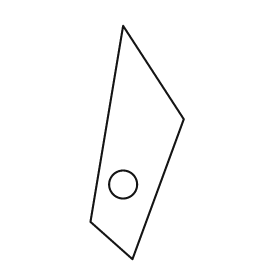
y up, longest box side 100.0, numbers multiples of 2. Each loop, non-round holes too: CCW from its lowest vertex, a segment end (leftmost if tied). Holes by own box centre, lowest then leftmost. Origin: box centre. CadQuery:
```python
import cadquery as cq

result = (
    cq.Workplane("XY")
    .moveTo(-2.0, -50.0)
    .lineTo(20.0, 10.0)
    .lineTo(-6.0, 50.0)
    .lineTo(-20.0, -34.0)
    .close()
    .moveTo(-6.0, -18.0)
    .circle(6.0)
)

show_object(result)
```